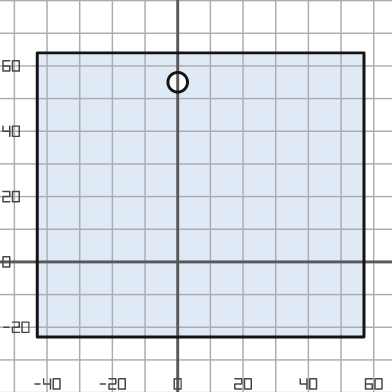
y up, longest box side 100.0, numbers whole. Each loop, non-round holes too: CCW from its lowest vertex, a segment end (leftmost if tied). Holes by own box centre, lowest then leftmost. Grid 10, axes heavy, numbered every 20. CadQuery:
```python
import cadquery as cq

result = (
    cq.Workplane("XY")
    .moveTo(-43.0, -23.0)
    .lineTo(57.0, -23.0)
    .lineTo(57.0, 64.0)
    .lineTo(-43.0, 64.0)
    .close()
    .moveTo(0.0, 55.0)
    .circle(3.0)
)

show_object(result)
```